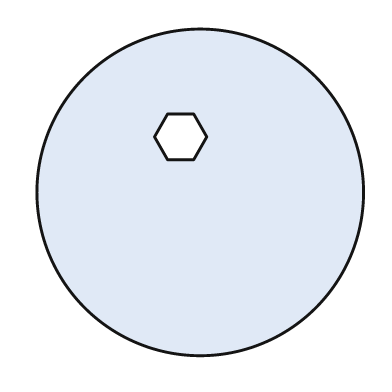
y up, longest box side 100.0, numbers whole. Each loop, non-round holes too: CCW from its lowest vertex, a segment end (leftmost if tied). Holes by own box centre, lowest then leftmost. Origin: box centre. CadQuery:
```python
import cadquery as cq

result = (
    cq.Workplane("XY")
    .moveTo(0.0, 0.0)
    .circle(50.0)
    .moveTo(-10.0, 10.0)
    .lineTo(-2.0, 10.0)
    .lineTo(2.0, 17.0)
    .lineTo(-2.0, 24.0)
    .lineTo(-10.0, 24.0)
    .lineTo(-14.0, 17.0)
    .close()
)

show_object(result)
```